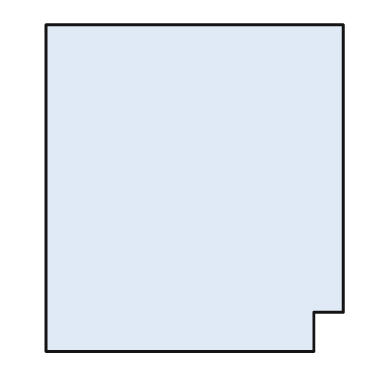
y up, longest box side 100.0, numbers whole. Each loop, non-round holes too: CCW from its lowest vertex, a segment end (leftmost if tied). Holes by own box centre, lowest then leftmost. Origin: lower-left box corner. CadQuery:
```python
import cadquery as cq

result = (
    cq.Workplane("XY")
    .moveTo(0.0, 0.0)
    .lineTo(82.0, 0.0)
    .lineTo(82.0, 12.0)
    .lineTo(91.0, 12.0)
    .lineTo(91.0, 100.0)
    .lineTo(0.0, 100.0)
    .close()
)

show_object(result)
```